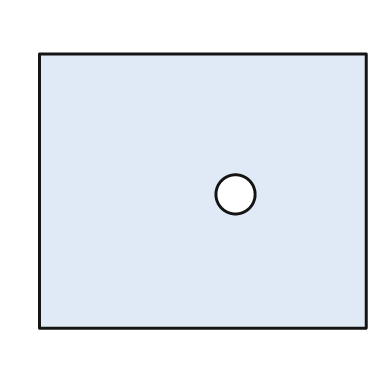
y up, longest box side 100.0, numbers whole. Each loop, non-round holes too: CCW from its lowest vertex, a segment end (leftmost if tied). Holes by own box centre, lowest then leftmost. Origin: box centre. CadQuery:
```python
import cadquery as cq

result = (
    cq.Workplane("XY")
    .moveTo(-50.0, -42.0)
    .lineTo(50.0, -42.0)
    .lineTo(50.0, 42.0)
    .lineTo(-50.0, 42.0)
    .close()
    .moveTo(10.0, -1.0)
    .circle(6.0)
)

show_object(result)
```